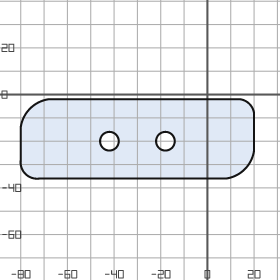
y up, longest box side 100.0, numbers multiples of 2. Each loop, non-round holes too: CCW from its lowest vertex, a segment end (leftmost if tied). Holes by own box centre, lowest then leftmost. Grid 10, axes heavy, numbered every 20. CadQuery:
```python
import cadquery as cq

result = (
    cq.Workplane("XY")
    .moveTo(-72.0, -36.0)
    .lineTo(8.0, -36.0)
    .threePointArc((16.0, -32.0), (20.0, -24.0))
    .lineTo(20.0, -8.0)
    .threePointArc((18.0, -4.0), (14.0, -2.0))
    .lineTo(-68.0, -2.0)
    .threePointArc((-76.0, -6.0), (-80.0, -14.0))
    .lineTo(-80.0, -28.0)
    .threePointArc((-78.0, -34.0), (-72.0, -36.0))
    .close()
    .moveTo(-42.0, -20.0)
    .circle(4.0)
    .moveTo(-18.0, -20.0)
    .circle(4.0)
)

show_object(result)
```